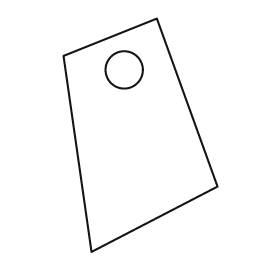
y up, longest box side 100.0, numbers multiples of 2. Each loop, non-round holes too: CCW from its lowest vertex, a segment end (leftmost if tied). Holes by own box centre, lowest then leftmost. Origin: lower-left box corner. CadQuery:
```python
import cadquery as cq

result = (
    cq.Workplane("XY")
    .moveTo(12.0, 0.0)
    .lineTo(66.0, 28.0)
    .lineTo(40.0, 100.0)
    .lineTo(0.0, 84.0)
    .close()
    .moveTo(26.0, 78.0)
    .circle(8.0)
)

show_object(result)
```